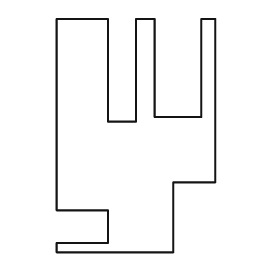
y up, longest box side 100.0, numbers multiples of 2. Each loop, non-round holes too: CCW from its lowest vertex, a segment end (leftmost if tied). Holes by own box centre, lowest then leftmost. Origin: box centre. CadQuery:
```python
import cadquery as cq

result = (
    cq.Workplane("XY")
    .moveTo(-34.0, -50.0)
    .lineTo(16.0, -50.0)
    .lineTo(16.0, -20.0)
    .lineTo(34.0, -20.0)
    .lineTo(34.0, 50.0)
    .lineTo(28.0, 50.0)
    .lineTo(28.0, 8.0)
    .lineTo(8.0, 8.0)
    .lineTo(8.0, 50.0)
    .lineTo(0.0, 50.0)
    .lineTo(0.0, 6.0)
    .lineTo(-12.0, 6.0)
    .lineTo(-12.0, 50.0)
    .lineTo(-34.0, 50.0)
    .lineTo(-34.0, -32.0)
    .lineTo(-12.0, -32.0)
    .lineTo(-12.0, -46.0)
    .lineTo(-34.0, -46.0)
    .close()
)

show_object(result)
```